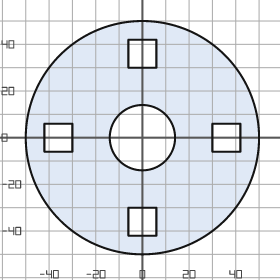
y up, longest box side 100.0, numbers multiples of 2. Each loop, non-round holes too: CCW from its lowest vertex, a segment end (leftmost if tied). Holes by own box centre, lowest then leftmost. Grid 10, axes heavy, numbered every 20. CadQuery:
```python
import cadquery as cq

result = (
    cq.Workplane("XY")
    .moveTo(0.0, 0.0)
    .circle(50.0)
    .moveTo(-6.0, -42.0)
    .lineTo(6.0, -42.0)
    .lineTo(6.0, -30.0)
    .lineTo(-6.0, -30.0)
    .close()
    .moveTo(-42.0, -6.0)
    .lineTo(-30.0, -6.0)
    .lineTo(-30.0, 6.0)
    .lineTo(-42.0, 6.0)
    .close()
    .moveTo(0.0, 0.0)
    .circle(14.0)
    .moveTo(30.0, -6.0)
    .lineTo(42.0, -6.0)
    .lineTo(42.0, 6.0)
    .lineTo(30.0, 6.0)
    .close()
    .moveTo(-6.0, 30.0)
    .lineTo(6.0, 30.0)
    .lineTo(6.0, 42.0)
    .lineTo(-6.0, 42.0)
    .close()
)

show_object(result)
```